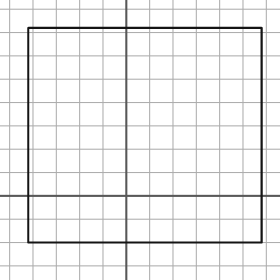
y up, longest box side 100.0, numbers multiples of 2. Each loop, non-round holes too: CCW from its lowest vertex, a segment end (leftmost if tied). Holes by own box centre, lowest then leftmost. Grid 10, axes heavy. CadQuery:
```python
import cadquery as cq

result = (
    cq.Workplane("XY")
    .moveTo(-42.0, -20.0)
    .lineTo(58.0, -20.0)
    .lineTo(58.0, 72.0)
    .lineTo(-42.0, 72.0)
    .close()
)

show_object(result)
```